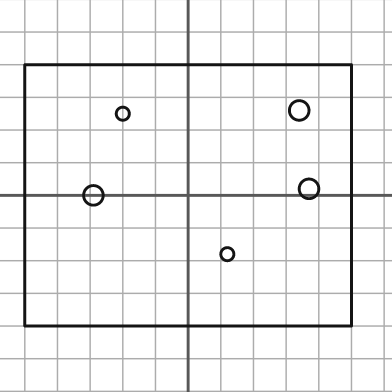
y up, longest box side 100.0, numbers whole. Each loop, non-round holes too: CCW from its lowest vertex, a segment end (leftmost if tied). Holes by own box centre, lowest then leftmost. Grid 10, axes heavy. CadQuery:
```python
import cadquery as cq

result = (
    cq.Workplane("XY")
    .moveTo(-50.0, -40.0)
    .lineTo(50.0, -40.0)
    .lineTo(50.0, 40.0)
    .lineTo(-50.0, 40.0)
    .close()
    .moveTo(12.0, -18.0)
    .circle(2.0)
    .moveTo(-29.0, 0.0)
    .circle(3.0)
    .moveTo(37.0, 2.0)
    .circle(3.0)
    .moveTo(-20.0, 25.0)
    .circle(2.0)
    .moveTo(34.0, 26.0)
    .circle(3.0)
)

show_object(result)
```